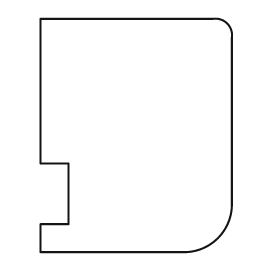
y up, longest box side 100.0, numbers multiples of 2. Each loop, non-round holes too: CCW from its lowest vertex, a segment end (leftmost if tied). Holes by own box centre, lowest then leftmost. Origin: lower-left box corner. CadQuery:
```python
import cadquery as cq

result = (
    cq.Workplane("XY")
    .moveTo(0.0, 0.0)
    .lineTo(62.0, 0.0)
    .threePointArc((76.0, 6.0), (82.0, 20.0))
    .lineTo(82.0, 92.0)
    .threePointArc((80.0, 98.0), (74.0, 100.0))
    .lineTo(0.0, 100.0)
    .lineTo(0.0, 38.0)
    .lineTo(12.0, 38.0)
    .lineTo(12.0, 12.0)
    .lineTo(0.0, 12.0)
    .close()
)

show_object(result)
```